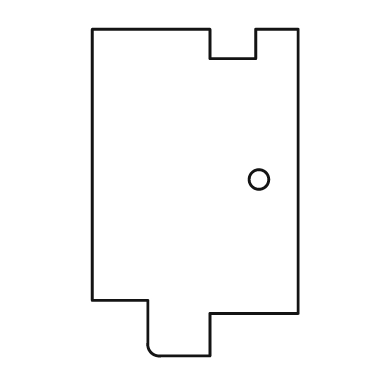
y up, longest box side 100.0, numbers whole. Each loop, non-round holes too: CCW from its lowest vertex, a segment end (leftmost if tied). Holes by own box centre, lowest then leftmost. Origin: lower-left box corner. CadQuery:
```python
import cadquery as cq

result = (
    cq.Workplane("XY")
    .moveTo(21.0, 0.0)
    .lineTo(36.0, 0.0)
    .lineTo(36.0, 13.0)
    .lineTo(63.0, 13.0)
    .lineTo(63.0, 100.0)
    .lineTo(50.0, 100.0)
    .lineTo(50.0, 91.0)
    .lineTo(36.0, 91.0)
    .lineTo(36.0, 100.0)
    .lineTo(0.0, 100.0)
    .lineTo(0.0, 17.0)
    .lineTo(17.0, 17.0)
    .lineTo(17.0, 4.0)
    .threePointArc((18.0, 1.0), (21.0, 0.0))
    .close()
    .moveTo(51.0, 54.0)
    .circle(3.0)
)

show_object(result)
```